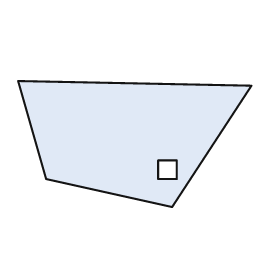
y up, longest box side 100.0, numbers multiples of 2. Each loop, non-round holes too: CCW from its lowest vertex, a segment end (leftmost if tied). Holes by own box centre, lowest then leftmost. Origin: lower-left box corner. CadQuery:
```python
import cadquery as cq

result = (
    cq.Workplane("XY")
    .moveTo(66.0, 0.0)
    .lineTo(100.0, 52.0)
    .lineTo(0.0, 54.0)
    .lineTo(12.0, 12.0)
    .close()
    .moveTo(60.0, 12.0)
    .lineTo(68.0, 12.0)
    .lineTo(68.0, 20.0)
    .lineTo(60.0, 20.0)
    .close()
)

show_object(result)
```